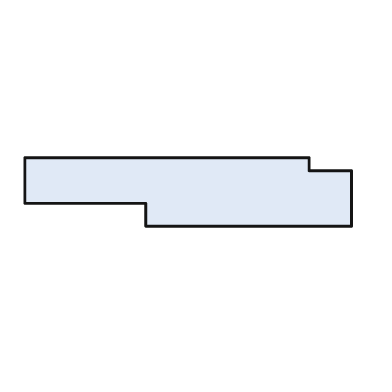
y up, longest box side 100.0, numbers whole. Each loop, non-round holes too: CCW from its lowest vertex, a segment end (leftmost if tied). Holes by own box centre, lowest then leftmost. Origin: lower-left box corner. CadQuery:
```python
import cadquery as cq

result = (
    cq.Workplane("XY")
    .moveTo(37.0, 0.0)
    .lineTo(100.0, 0.0)
    .lineTo(100.0, 17.0)
    .lineTo(87.0, 17.0)
    .lineTo(87.0, 21.0)
    .lineTo(0.0, 21.0)
    .lineTo(0.0, 7.0)
    .lineTo(37.0, 7.0)
    .close()
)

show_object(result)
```